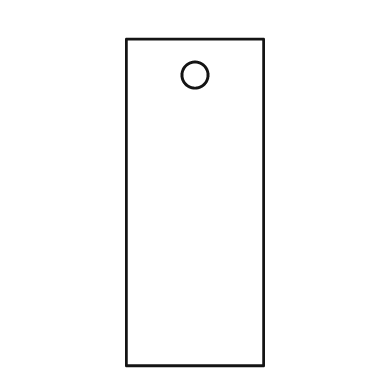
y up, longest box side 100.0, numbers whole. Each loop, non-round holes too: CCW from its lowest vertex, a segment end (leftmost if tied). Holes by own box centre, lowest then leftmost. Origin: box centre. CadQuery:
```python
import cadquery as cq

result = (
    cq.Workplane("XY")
    .moveTo(-21.0, -50.0)
    .lineTo(21.0, -50.0)
    .lineTo(21.0, 50.0)
    .lineTo(-21.0, 50.0)
    .close()
    .moveTo(0.0, 39.0)
    .circle(4.0)
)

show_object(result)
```